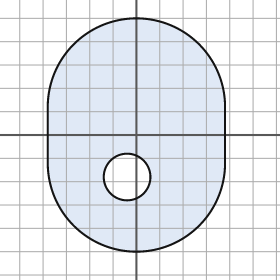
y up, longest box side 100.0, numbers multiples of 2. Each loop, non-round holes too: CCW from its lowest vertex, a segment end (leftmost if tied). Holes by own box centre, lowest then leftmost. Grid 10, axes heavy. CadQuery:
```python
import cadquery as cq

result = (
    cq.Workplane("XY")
    .moveTo(-38.0, -12.0)
    .threePointArc((0.0, -50.0), (38.0, -12.0))
    .lineTo(38.0, 12.0)
    .threePointArc((0.0, 50.0), (-38.0, 12.0))
    .close()
    .moveTo(-4.0, -18.0)
    .circle(10.0)
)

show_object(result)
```